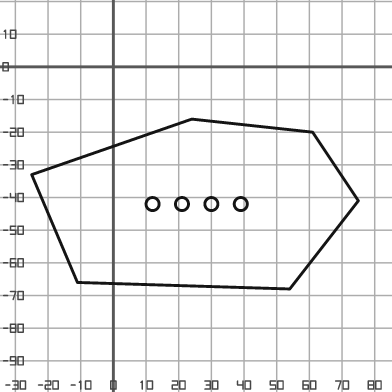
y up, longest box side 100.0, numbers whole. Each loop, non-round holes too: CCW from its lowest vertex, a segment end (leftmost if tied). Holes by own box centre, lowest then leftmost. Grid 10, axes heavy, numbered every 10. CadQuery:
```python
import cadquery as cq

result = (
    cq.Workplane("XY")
    .moveTo(54.0, -68.0)
    .lineTo(75.0, -41.0)
    .lineTo(61.0, -20.0)
    .lineTo(24.0, -16.0)
    .lineTo(-25.0, -33.0)
    .lineTo(-11.0, -66.0)
    .close()
    .moveTo(12.0, -42.0)
    .circle(2.0)
    .moveTo(21.0, -42.0)
    .circle(2.0)
    .moveTo(30.0, -42.0)
    .circle(2.0)
    .moveTo(39.0, -42.0)
    .circle(2.0)
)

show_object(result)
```